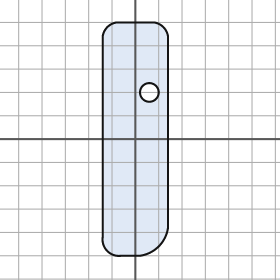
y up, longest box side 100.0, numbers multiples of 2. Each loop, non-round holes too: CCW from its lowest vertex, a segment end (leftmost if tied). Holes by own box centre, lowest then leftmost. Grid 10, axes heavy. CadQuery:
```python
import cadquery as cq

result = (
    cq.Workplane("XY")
    .moveTo(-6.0, -50.0)
    .lineTo(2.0, -50.0)
    .threePointArc((10.0, -46.0), (14.0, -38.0))
    .lineTo(14.0, 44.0)
    .threePointArc((12.0, 48.0), (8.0, 50.0))
    .lineTo(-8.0, 50.0)
    .threePointArc((-12.0, 48.0), (-14.0, 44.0))
    .lineTo(-14.0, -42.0)
    .threePointArc((-12.0, -48.0), (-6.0, -50.0))
    .close()
    .moveTo(6.0, 20.0)
    .circle(4.0)
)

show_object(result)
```